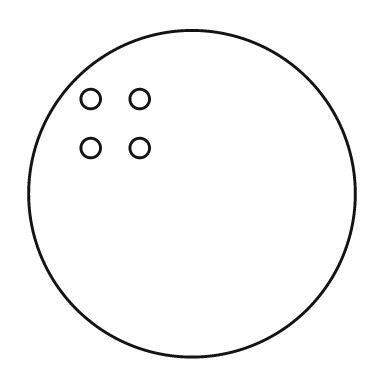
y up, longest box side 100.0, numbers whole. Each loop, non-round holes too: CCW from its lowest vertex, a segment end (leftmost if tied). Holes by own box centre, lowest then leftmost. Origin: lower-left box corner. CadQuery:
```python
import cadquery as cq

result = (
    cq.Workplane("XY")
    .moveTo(50.0, 50.0)
    .circle(50.0)
    .moveTo(19.0, 64.0)
    .circle(3.0)
    .moveTo(34.0, 64.0)
    .circle(3.0)
    .moveTo(19.0, 79.0)
    .circle(3.0)
    .moveTo(34.0, 79.0)
    .circle(3.0)
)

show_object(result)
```